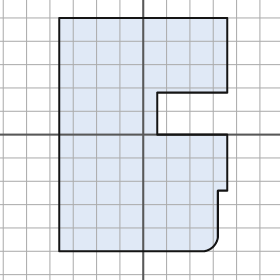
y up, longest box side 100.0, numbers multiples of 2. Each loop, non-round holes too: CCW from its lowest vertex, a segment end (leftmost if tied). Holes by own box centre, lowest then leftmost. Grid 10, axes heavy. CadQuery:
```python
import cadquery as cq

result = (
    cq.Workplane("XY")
    .moveTo(-36.0, -50.0)
    .lineTo(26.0, -50.0)
    .threePointArc((30.0, -48.0), (32.0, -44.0))
    .lineTo(32.0, -24.0)
    .lineTo(36.0, -24.0)
    .lineTo(36.0, 0.0)
    .lineTo(6.0, 0.0)
    .lineTo(6.0, 18.0)
    .lineTo(36.0, 18.0)
    .lineTo(36.0, 50.0)
    .lineTo(-36.0, 50.0)
    .close()
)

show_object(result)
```